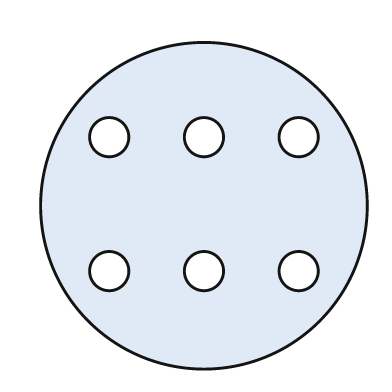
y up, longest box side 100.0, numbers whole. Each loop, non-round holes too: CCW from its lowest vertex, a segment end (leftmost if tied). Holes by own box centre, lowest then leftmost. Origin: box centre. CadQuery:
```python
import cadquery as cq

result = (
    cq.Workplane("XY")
    .moveTo(0.0, 0.0)
    .circle(50.0)
    .moveTo(-29.0, -20.0)
    .circle(6.0)
    .moveTo(0.0, -20.0)
    .circle(6.0)
    .moveTo(29.0, -20.0)
    .circle(6.0)
    .moveTo(-29.0, 21.0)
    .circle(6.0)
    .moveTo(0.0, 21.0)
    .circle(6.0)
    .moveTo(29.0, 21.0)
    .circle(6.0)
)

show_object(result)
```